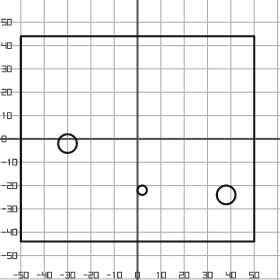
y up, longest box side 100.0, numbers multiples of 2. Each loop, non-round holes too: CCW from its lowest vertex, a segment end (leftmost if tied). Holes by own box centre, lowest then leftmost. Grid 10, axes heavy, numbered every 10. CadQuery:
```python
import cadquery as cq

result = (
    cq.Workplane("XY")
    .moveTo(-50.0, -44.0)
    .lineTo(50.0, -44.0)
    .lineTo(50.0, 44.0)
    .lineTo(-50.0, 44.0)
    .close()
    .moveTo(38.0, -24.0)
    .circle(4.0)
    .moveTo(2.0, -22.0)
    .circle(2.0)
    .moveTo(-30.0, -2.0)
    .circle(4.0)
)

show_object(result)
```